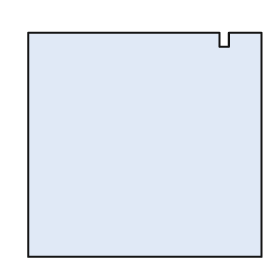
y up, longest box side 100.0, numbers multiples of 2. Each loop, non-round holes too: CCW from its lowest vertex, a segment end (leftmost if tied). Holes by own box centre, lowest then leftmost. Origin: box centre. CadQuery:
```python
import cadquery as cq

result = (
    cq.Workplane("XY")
    .moveTo(-50.0, -48.0)
    .lineTo(50.0, -48.0)
    .lineTo(50.0, 48.0)
    .lineTo(36.0, 48.0)
    .lineTo(36.0, 42.0)
    .lineTo(32.0, 42.0)
    .lineTo(32.0, 48.0)
    .lineTo(-50.0, 48.0)
    .close()
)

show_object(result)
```